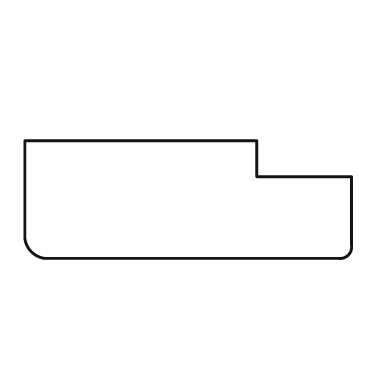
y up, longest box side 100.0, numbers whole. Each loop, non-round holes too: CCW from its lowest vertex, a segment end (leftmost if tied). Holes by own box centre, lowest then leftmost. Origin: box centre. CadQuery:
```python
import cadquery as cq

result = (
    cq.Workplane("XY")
    .moveTo(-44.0, -18.0)
    .lineTo(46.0, -18.0)
    .threePointArc((49.0, -17.0), (50.0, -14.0))
    .lineTo(50.0, 7.0)
    .lineTo(21.0, 7.0)
    .lineTo(21.0, 18.0)
    .lineTo(-50.0, 18.0)
    .lineTo(-50.0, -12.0)
    .threePointArc((-48.0, -16.0), (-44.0, -18.0))
    .close()
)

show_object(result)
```